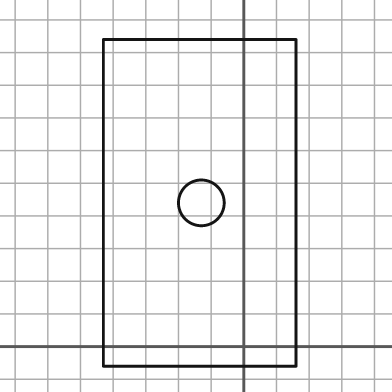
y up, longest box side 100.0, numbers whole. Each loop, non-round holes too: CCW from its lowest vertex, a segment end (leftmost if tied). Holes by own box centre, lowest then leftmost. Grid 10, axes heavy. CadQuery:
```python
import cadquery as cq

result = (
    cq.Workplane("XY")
    .moveTo(-43.0, -6.0)
    .lineTo(16.0, -6.0)
    .lineTo(16.0, 94.0)
    .lineTo(-43.0, 94.0)
    .close()
    .moveTo(-13.0, 44.0)
    .circle(7.0)
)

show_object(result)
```